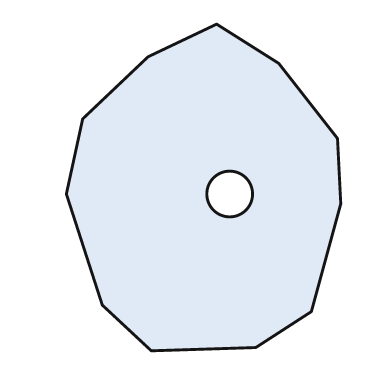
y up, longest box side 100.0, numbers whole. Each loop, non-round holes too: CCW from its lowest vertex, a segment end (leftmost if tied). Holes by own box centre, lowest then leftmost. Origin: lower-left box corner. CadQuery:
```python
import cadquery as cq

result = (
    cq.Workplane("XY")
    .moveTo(26.0, 0.0)
    .lineTo(58.0, 1.0)
    .lineTo(75.0, 12.0)
    .lineTo(84.0, 45.0)
    .lineTo(83.0, 65.0)
    .lineTo(65.0, 88.0)
    .lineTo(46.0, 100.0)
    .lineTo(25.0, 90.0)
    .lineTo(5.0, 71.0)
    .lineTo(0.0, 48.0)
    .lineTo(11.0, 14.0)
    .close()
    .moveTo(50.0, 48.0)
    .circle(7.0)
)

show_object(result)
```